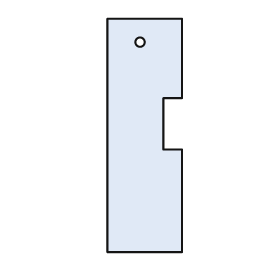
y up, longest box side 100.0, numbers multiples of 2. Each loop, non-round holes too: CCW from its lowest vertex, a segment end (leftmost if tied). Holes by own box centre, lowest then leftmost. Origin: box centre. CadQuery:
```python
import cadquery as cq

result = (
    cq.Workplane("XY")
    .moveTo(-16.0, -50.0)
    .lineTo(16.0, -50.0)
    .lineTo(16.0, -6.0)
    .lineTo(8.0, -6.0)
    .lineTo(8.0, 16.0)
    .lineTo(16.0, 16.0)
    .lineTo(16.0, 50.0)
    .lineTo(-16.0, 50.0)
    .close()
    .moveTo(-2.0, 40.0)
    .circle(2.0)
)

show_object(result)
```